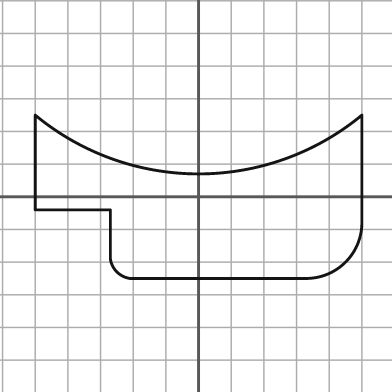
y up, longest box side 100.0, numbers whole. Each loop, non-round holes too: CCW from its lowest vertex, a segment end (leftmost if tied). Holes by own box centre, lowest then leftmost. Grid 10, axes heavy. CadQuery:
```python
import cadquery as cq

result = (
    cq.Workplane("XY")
    .moveTo(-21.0, -25.0)
    .lineTo(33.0, -25.0)
    .threePointArc((45.0, -20.0), (50.0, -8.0))
    .lineTo(50.0, 25.0)
    .threePointArc((0.0, 7.0), (-50.0, 25.0))
    .lineTo(-50.0, -4.0)
    .lineTo(-27.0, -4.0)
    .lineTo(-27.0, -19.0)
    .threePointArc((-25.0, -23.0), (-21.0, -25.0))
    .close()
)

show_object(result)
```